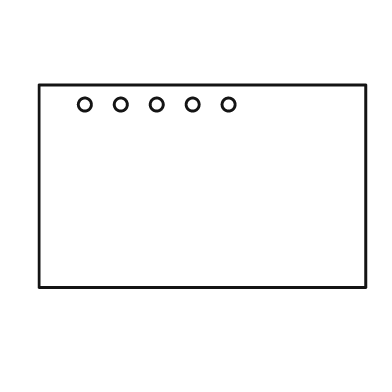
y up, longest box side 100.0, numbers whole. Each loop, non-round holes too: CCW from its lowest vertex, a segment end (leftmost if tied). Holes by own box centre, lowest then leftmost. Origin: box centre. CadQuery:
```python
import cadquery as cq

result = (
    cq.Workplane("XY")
    .moveTo(-50.0, -31.0)
    .lineTo(50.0, -31.0)
    .lineTo(50.0, 31.0)
    .lineTo(-50.0, 31.0)
    .close()
    .moveTo(-36.0, 25.0)
    .circle(2.0)
    .moveTo(-25.0, 25.0)
    .circle(2.0)
    .moveTo(-14.0, 25.0)
    .circle(2.0)
    .moveTo(-3.0, 25.0)
    .circle(2.0)
    .moveTo(8.0, 25.0)
    .circle(2.0)
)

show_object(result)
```